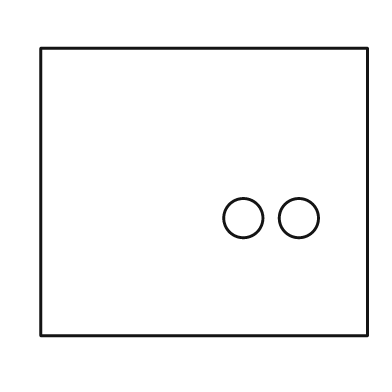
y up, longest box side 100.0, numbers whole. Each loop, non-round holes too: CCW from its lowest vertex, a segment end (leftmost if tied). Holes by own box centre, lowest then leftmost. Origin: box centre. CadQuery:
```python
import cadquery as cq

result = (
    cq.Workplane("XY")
    .moveTo(-50.0, -44.0)
    .lineTo(50.0, -44.0)
    .lineTo(50.0, 44.0)
    .lineTo(-50.0, 44.0)
    .close()
    .moveTo(12.0, -8.0)
    .circle(6.0)
    .moveTo(29.0, -8.0)
    .circle(6.0)
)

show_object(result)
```